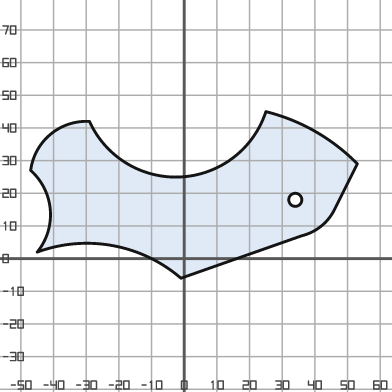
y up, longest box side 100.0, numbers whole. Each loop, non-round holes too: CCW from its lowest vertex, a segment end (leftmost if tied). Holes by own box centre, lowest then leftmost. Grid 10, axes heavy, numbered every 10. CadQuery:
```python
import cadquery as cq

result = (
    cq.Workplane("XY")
    .moveTo(-1.0, -6.0)
    .lineTo(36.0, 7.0)
    .threePointArc((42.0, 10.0), (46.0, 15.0))
    .lineTo(53.0, 29.0)
    .threePointArc((40.0, 39.0), (25.0, 45.0))
    .threePointArc((-1.0, 25.0), (-29.0, 42.0))
    .threePointArc((-41.0, 38.0), (-47.0, 27.0))
    .threePointArc((-41.0, 15.0), (-45.0, 2.0))
    .threePointArc((-22.0, 4.0), (-1.0, -6.0))
    .close()
    .moveTo(34.0, 18.0)
    .circle(2.0)
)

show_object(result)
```